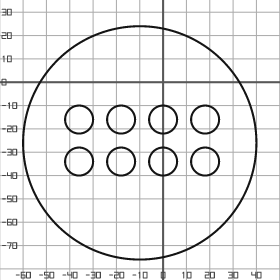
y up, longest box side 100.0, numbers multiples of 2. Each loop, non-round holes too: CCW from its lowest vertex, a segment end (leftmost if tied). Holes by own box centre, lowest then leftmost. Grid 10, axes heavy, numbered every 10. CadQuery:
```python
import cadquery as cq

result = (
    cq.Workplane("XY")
    .moveTo(-10.0, -26.0)
    .circle(50.0)
    .moveTo(-36.0, -34.0)
    .circle(6.0)
    .moveTo(-18.0, -34.0)
    .circle(6.0)
    .moveTo(0.0, -34.0)
    .circle(6.0)
    .moveTo(18.0, -34.0)
    .circle(6.0)
    .moveTo(-36.0, -16.0)
    .circle(6.0)
    .moveTo(-18.0, -16.0)
    .circle(6.0)
    .moveTo(0.0, -16.0)
    .circle(6.0)
    .moveTo(18.0, -16.0)
    .circle(6.0)
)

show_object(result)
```